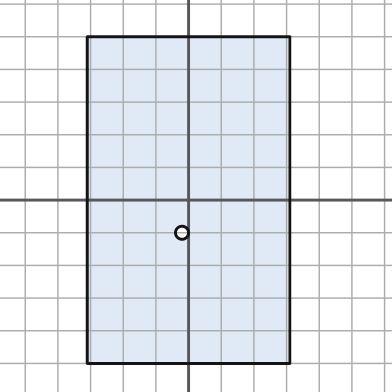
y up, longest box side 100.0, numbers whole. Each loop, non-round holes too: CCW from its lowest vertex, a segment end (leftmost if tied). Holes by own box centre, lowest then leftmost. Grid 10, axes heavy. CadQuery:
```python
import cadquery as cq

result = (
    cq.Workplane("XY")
    .moveTo(-31.0, -50.0)
    .lineTo(31.0, -50.0)
    .lineTo(31.0, 50.0)
    .lineTo(-31.0, 50.0)
    .close()
    .moveTo(-2.0, -10.0)
    .circle(2.0)
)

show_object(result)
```